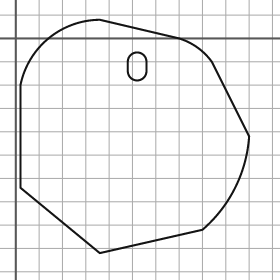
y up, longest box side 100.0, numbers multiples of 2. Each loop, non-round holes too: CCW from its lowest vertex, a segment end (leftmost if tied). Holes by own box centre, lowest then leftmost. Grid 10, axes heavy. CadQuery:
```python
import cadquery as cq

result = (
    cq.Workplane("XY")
    .moveTo(36.0, -92.0)
    .lineTo(80.0, -82.0)
    .threePointArc((94.0, -64.0), (100.0, -42.0))
    .lineTo(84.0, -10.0)
    .threePointArc((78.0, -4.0), (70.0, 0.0))
    .lineTo(36.0, 8.0)
    .threePointArc((14.0, 0.0), (2.0, -20.0))
    .lineTo(2.0, -64.0)
    .close()
    .moveTo(48.0, -14.0)
    .threePointArc((52.0, -18.0), (56.0, -14.0))
    .lineTo(56.0, -10.0)
    .threePointArc((52.0, -6.0), (48.0, -10.0))
    .close()
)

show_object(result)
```